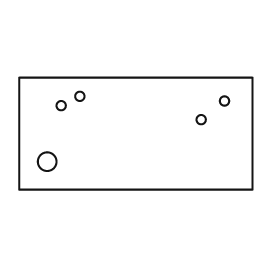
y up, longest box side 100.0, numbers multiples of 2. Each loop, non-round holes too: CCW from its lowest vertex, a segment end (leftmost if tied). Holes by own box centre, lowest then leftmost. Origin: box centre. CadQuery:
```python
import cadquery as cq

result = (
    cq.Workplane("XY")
    .moveTo(-50.0, -24.0)
    .lineTo(50.0, -24.0)
    .lineTo(50.0, 24.0)
    .lineTo(-50.0, 24.0)
    .close()
    .moveTo(-38.0, -12.0)
    .circle(4.0)
    .moveTo(28.0, 6.0)
    .circle(2.0)
    .moveTo(-32.0, 12.0)
    .circle(2.0)
    .moveTo(38.0, 14.0)
    .circle(2.0)
    .moveTo(-24.0, 16.0)
    .circle(2.0)
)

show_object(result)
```